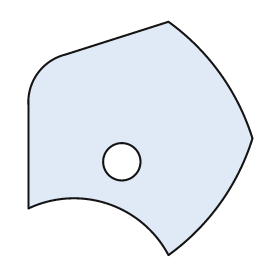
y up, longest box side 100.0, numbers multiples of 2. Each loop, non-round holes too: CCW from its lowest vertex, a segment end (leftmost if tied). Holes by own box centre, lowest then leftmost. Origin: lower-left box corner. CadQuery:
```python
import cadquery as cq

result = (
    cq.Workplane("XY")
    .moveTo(60.0, 0.0)
    .threePointArc((82.0, 22.0), (96.0, 50.0))
    .threePointArc((82.0, 78.0), (60.0, 100.0))
    .lineTo(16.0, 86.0)
    .threePointArc((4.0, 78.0), (0.0, 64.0))
    .lineTo(0.0, 20.0)
    .threePointArc((34.0, 22.0), (60.0, 0.0))
    .close()
    .moveTo(40.0, 40.0)
    .circle(8.0)
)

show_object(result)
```